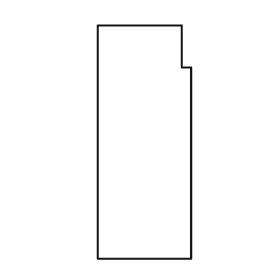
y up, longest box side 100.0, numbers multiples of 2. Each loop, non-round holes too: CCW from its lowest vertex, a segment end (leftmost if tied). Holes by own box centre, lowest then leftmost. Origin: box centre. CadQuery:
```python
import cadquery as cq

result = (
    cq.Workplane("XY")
    .moveTo(-20.0, -50.0)
    .lineTo(20.0, -50.0)
    .lineTo(20.0, 32.0)
    .lineTo(16.0, 32.0)
    .lineTo(16.0, 50.0)
    .lineTo(-20.0, 50.0)
    .close()
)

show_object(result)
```